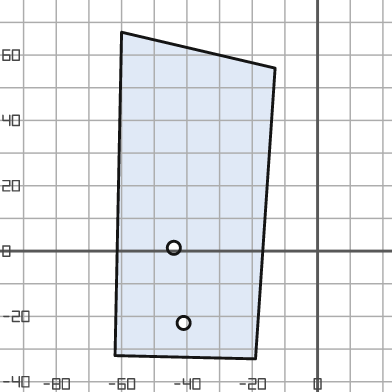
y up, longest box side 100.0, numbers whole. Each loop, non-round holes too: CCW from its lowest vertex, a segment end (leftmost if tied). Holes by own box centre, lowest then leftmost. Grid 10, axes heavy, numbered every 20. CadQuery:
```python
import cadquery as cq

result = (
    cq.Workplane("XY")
    .moveTo(-19.0, -33.0)
    .lineTo(-13.0, 56.0)
    .lineTo(-60.0, 67.0)
    .lineTo(-62.0, -32.0)
    .close()
    .moveTo(-41.0, -22.0)
    .circle(2.0)
    .moveTo(-44.0, 1.0)
    .circle(2.0)
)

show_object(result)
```